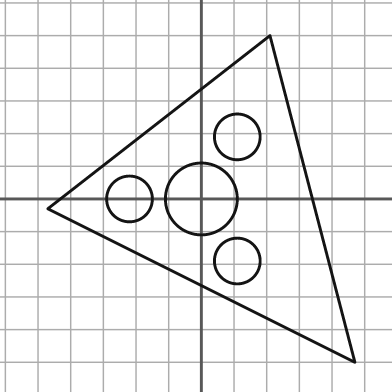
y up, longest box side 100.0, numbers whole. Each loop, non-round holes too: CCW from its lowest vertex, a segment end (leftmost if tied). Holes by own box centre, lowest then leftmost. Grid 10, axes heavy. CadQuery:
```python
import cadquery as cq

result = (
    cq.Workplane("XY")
    .moveTo(47.0, -50.0)
    .lineTo(21.0, 50.0)
    .lineTo(-47.0, -3.0)
    .close()
    .moveTo(11.0, -19.0)
    .circle(7.0)
    .moveTo(-22.0, 0.0)
    .circle(7.0)
    .moveTo(0.0, 0.0)
    .circle(11.0)
    .moveTo(11.0, 19.0)
    .circle(7.0)
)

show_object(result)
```